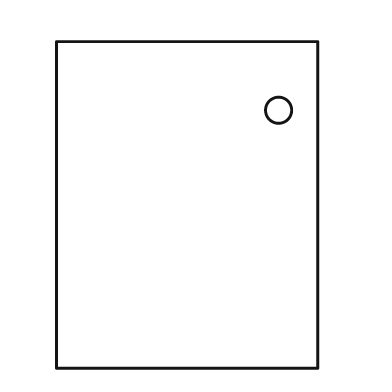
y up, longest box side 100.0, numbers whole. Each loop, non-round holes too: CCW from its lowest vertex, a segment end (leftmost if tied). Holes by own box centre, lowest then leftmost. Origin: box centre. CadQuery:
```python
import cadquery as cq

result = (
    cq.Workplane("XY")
    .moveTo(-40.0, -50.0)
    .lineTo(40.0, -50.0)
    .lineTo(40.0, 50.0)
    .lineTo(-40.0, 50.0)
    .close()
    .moveTo(28.0, 29.0)
    .circle(4.0)
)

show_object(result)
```